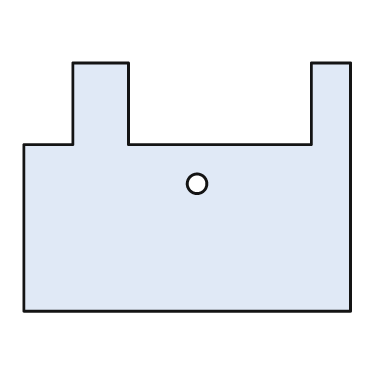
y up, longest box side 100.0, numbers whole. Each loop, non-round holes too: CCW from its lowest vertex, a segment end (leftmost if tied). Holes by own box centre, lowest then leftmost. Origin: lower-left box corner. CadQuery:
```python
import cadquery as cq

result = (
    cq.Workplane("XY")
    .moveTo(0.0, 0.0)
    .lineTo(100.0, 0.0)
    .lineTo(100.0, 76.0)
    .lineTo(88.0, 76.0)
    .lineTo(88.0, 51.0)
    .lineTo(32.0, 51.0)
    .lineTo(32.0, 76.0)
    .lineTo(15.0, 76.0)
    .lineTo(15.0, 51.0)
    .lineTo(0.0, 51.0)
    .close()
    .moveTo(53.0, 39.0)
    .circle(3.0)
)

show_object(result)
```